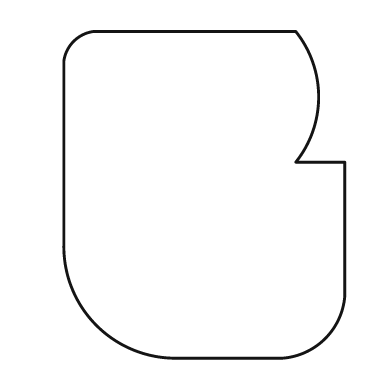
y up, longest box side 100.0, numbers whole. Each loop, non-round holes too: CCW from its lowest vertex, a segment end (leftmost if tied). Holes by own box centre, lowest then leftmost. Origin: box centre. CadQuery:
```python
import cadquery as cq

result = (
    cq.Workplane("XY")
    .moveTo(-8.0, -50.0)
    .lineTo(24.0, -50.0)
    .threePointArc((37.0, -44.0), (43.0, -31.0))
    .lineTo(43.0, 10.0)
    .lineTo(28.0, 10.0)
    .threePointArc((35.0, 30.0), (28.0, 50.0))
    .lineTo(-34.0, 50.0)
    .threePointArc((-40.0, 47.0), (-43.0, 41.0))
    .lineTo(-43.0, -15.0)
    .threePointArc((-33.0, -40.0), (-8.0, -50.0))
    .close()
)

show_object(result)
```